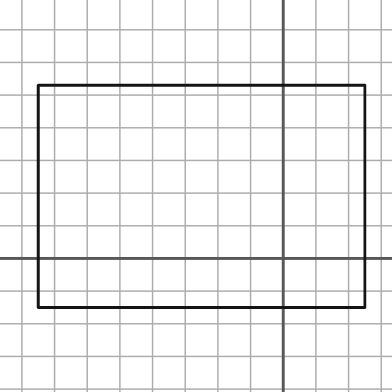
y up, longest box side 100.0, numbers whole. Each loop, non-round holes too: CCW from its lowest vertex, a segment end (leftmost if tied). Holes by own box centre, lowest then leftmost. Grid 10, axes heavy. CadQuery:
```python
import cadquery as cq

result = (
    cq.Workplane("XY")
    .moveTo(-75.0, -15.0)
    .lineTo(25.0, -15.0)
    .lineTo(25.0, 53.0)
    .lineTo(-75.0, 53.0)
    .close()
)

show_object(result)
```